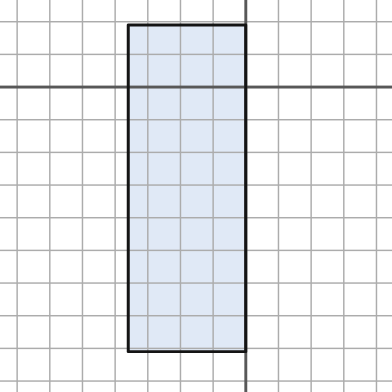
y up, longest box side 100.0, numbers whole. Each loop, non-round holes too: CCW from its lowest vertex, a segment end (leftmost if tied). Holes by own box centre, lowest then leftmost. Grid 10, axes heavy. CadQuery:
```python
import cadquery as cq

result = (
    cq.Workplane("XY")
    .moveTo(-36.0, -81.0)
    .lineTo(0.0, -81.0)
    .lineTo(0.0, 19.0)
    .lineTo(-36.0, 19.0)
    .close()
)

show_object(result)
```